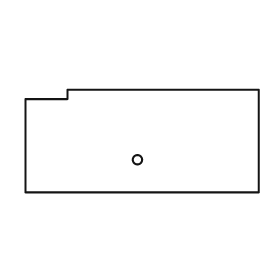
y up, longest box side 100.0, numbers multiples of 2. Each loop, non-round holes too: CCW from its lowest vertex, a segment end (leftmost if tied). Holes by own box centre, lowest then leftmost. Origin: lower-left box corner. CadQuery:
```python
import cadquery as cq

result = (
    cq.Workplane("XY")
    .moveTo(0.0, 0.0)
    .lineTo(100.0, 0.0)
    .lineTo(100.0, 44.0)
    .lineTo(18.0, 44.0)
    .lineTo(18.0, 40.0)
    .lineTo(0.0, 40.0)
    .close()
    .moveTo(48.0, 14.0)
    .circle(2.0)
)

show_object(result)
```